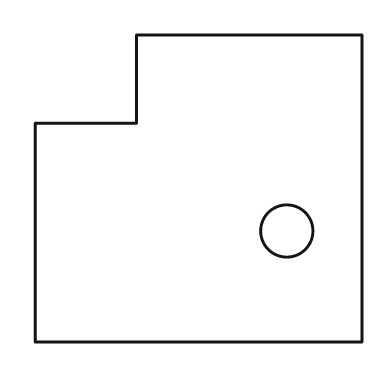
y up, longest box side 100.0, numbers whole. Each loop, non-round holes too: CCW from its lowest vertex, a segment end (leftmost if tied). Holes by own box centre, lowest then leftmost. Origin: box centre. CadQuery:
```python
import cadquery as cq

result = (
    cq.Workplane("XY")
    .moveTo(-50.0, -47.0)
    .lineTo(50.0, -47.0)
    .lineTo(50.0, 47.0)
    .lineTo(-19.0, 47.0)
    .lineTo(-19.0, 20.0)
    .lineTo(-50.0, 20.0)
    .close()
    .moveTo(27.0, -13.0)
    .circle(8.0)
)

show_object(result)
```